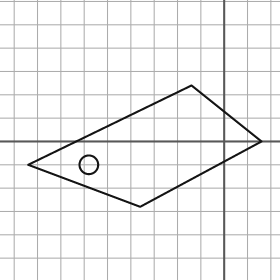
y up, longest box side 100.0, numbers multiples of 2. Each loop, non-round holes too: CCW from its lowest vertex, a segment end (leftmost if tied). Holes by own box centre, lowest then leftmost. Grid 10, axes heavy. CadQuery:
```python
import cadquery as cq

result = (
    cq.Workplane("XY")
    .moveTo(-36.0, -28.0)
    .lineTo(16.0, 0.0)
    .lineTo(-14.0, 24.0)
    .lineTo(-84.0, -10.0)
    .close()
    .moveTo(-58.0, -10.0)
    .circle(4.0)
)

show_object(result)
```